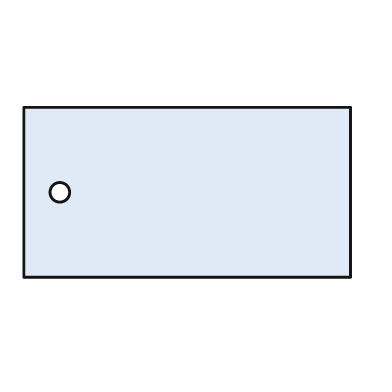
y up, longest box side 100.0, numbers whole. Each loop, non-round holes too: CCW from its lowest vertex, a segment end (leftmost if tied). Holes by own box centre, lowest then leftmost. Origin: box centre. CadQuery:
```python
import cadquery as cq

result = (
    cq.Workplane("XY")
    .moveTo(-50.0, -26.0)
    .lineTo(50.0, -26.0)
    .lineTo(50.0, 26.0)
    .lineTo(-50.0, 26.0)
    .close()
    .moveTo(-39.0, 0.0)
    .circle(3.0)
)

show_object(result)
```